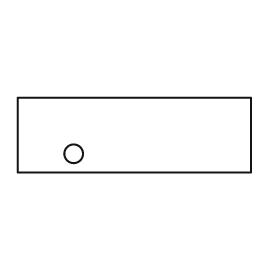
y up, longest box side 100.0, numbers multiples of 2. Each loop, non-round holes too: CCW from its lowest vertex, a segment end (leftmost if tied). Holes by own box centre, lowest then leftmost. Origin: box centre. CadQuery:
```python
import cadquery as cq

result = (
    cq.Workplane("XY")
    .moveTo(-50.0, -16.0)
    .lineTo(50.0, -16.0)
    .lineTo(50.0, 16.0)
    .lineTo(-50.0, 16.0)
    .close()
    .moveTo(-26.0, -8.0)
    .circle(4.0)
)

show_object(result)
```